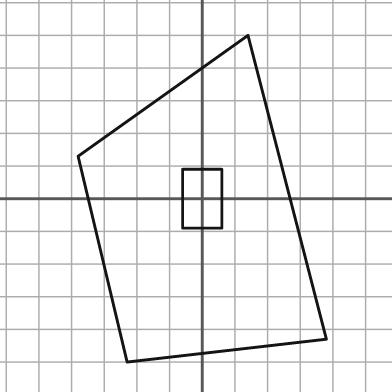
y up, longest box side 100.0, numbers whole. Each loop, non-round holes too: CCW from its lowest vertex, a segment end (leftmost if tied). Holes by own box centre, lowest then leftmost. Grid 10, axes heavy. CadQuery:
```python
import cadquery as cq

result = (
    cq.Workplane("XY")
    .moveTo(-23.0, -50.0)
    .lineTo(38.0, -43.0)
    .lineTo(14.0, 50.0)
    .lineTo(-38.0, 13.0)
    .close()
    .moveTo(-6.0, -9.0)
    .lineTo(6.0, -9.0)
    .lineTo(6.0, 9.0)
    .lineTo(-6.0, 9.0)
    .close()
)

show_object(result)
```